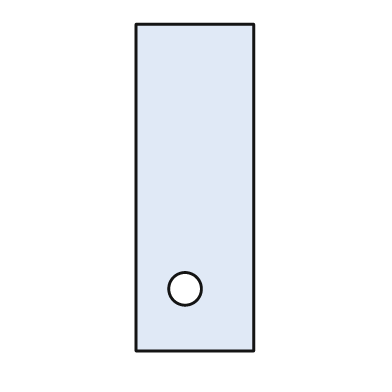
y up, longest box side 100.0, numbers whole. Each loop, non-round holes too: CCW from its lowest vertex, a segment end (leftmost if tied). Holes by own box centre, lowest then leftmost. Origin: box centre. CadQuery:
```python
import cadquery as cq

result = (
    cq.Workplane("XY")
    .moveTo(-18.0, -50.0)
    .lineTo(18.0, -50.0)
    .lineTo(18.0, 50.0)
    .lineTo(-18.0, 50.0)
    .close()
    .moveTo(-3.0, -31.0)
    .circle(5.0)
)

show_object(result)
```